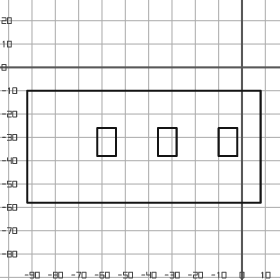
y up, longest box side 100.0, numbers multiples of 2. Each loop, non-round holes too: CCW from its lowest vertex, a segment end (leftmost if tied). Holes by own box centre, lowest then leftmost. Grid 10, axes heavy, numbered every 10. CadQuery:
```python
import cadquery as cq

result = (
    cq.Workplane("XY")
    .moveTo(-92.0, -58.0)
    .lineTo(8.0, -58.0)
    .lineTo(8.0, -10.0)
    .lineTo(-92.0, -10.0)
    .close()
    .moveTo(-62.0, -38.0)
    .lineTo(-54.0, -38.0)
    .lineTo(-54.0, -26.0)
    .lineTo(-62.0, -26.0)
    .close()
    .moveTo(-36.0, -38.0)
    .lineTo(-28.0, -38.0)
    .lineTo(-28.0, -26.0)
    .lineTo(-36.0, -26.0)
    .close()
    .moveTo(-10.0, -38.0)
    .lineTo(-2.0, -38.0)
    .lineTo(-2.0, -26.0)
    .lineTo(-10.0, -26.0)
    .close()
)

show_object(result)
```